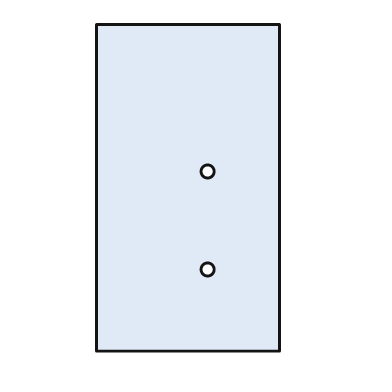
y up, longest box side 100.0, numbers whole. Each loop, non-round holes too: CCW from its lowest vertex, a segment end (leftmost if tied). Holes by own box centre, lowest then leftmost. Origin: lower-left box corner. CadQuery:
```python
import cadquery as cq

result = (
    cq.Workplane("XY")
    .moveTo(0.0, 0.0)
    .lineTo(56.0, 0.0)
    .lineTo(56.0, 100.0)
    .lineTo(0.0, 100.0)
    .close()
    .moveTo(34.0, 25.0)
    .circle(2.0)
    .moveTo(34.0, 55.0)
    .circle(2.0)
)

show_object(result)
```